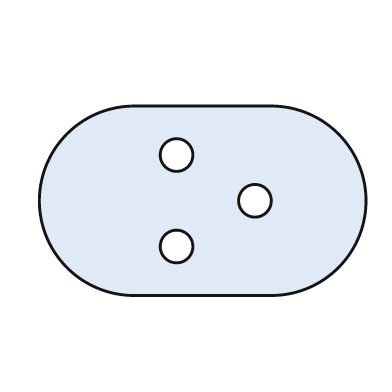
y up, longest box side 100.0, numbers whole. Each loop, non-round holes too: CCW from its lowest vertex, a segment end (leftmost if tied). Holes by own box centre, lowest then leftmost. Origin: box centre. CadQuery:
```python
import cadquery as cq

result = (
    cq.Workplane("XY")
    .moveTo(-21.0, -29.0)
    .lineTo(21.0, -29.0)
    .threePointArc((50.0, 0.0), (21.0, 29.0))
    .lineTo(-21.0, 29.0)
    .threePointArc((-50.0, 0.0), (-21.0, -29.0))
    .close()
    .moveTo(-8.0, -14.0)
    .circle(5.0)
    .moveTo(16.0, 0.0)
    .circle(5.0)
    .moveTo(-8.0, 14.0)
    .circle(5.0)
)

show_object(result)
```